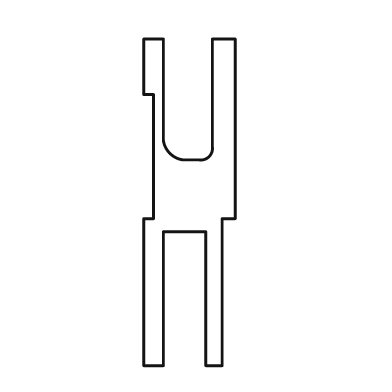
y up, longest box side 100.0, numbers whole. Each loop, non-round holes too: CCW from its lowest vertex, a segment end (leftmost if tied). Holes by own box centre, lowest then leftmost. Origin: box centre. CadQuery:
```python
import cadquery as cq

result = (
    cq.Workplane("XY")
    .moveTo(-14.0, -50.0)
    .lineTo(-8.0, -50.0)
    .lineTo(-8.0, -9.0)
    .lineTo(5.0, -9.0)
    .lineTo(5.0, -50.0)
    .lineTo(10.0, -50.0)
    .lineTo(10.0, -5.0)
    .lineTo(14.0, -5.0)
    .lineTo(14.0, 50.0)
    .lineTo(7.0, 50.0)
    .lineTo(7.0, 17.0)
    .threePointArc((6.0, 14.0), (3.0, 13.0))
    .lineTo(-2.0, 13.0)
    .threePointArc((-6.0, 15.0), (-8.0, 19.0))
    .lineTo(-8.0, 50.0)
    .lineTo(-14.0, 50.0)
    .lineTo(-14.0, 33.0)
    .lineTo(-11.0, 33.0)
    .lineTo(-11.0, -5.0)
    .lineTo(-14.0, -5.0)
    .close()
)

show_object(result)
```